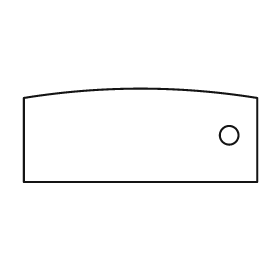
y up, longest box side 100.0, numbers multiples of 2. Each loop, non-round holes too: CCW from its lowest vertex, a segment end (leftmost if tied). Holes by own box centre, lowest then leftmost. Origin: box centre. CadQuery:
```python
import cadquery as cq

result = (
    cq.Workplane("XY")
    .moveTo(-50.0, -20.0)
    .lineTo(50.0, -20.0)
    .lineTo(50.0, 16.0)
    .threePointArc((0.0, 20.0), (-50.0, 16.0))
    .close()
    .moveTo(38.0, 0.0)
    .circle(4.0)
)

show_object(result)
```